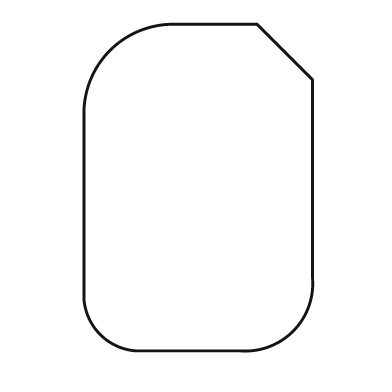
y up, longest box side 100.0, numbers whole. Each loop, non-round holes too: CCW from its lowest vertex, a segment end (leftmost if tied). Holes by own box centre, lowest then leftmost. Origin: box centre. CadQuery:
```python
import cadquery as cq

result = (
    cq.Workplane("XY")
    .moveTo(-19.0, -50.0)
    .lineTo(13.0, -50.0)
    .threePointArc((29.0, -44.0), (35.0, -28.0))
    .lineTo(35.0, 33.0)
    .lineTo(18.0, 50.0)
    .lineTo(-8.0, 50.0)
    .threePointArc((-27.0, 42.0), (-35.0, 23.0))
    .lineTo(-35.0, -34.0)
    .threePointArc((-30.0, -45.0), (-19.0, -50.0))
    .close()
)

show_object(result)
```